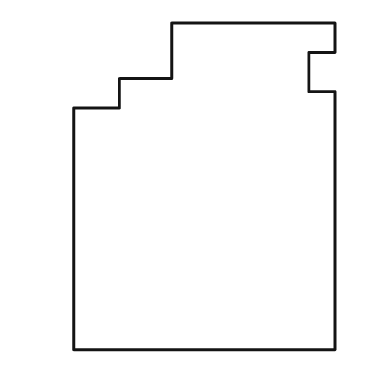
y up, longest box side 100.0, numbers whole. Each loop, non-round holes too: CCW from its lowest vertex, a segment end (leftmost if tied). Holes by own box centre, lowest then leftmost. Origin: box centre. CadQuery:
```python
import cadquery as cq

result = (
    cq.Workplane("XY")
    .moveTo(-40.0, -50.0)
    .lineTo(40.0, -50.0)
    .lineTo(40.0, 29.0)
    .lineTo(32.0, 29.0)
    .lineTo(32.0, 41.0)
    .lineTo(40.0, 41.0)
    .lineTo(40.0, 50.0)
    .lineTo(-10.0, 50.0)
    .lineTo(-10.0, 33.0)
    .lineTo(-26.0, 33.0)
    .lineTo(-26.0, 24.0)
    .lineTo(-40.0, 24.0)
    .close()
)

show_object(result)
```